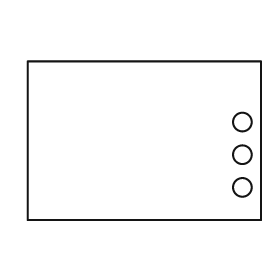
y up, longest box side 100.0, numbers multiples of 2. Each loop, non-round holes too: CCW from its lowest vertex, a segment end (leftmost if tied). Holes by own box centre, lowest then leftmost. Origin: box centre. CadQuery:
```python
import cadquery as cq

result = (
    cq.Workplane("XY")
    .moveTo(-50.0, -34.0)
    .lineTo(50.0, -34.0)
    .lineTo(50.0, 34.0)
    .lineTo(-50.0, 34.0)
    .close()
    .moveTo(42.0, -20.0)
    .circle(4.0)
    .moveTo(42.0, -6.0)
    .circle(4.0)
    .moveTo(42.0, 8.0)
    .circle(4.0)
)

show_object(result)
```